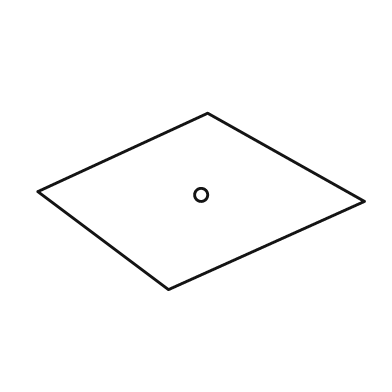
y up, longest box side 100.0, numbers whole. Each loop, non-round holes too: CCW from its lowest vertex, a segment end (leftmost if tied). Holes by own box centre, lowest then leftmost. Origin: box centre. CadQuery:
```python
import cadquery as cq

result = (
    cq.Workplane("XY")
    .moveTo(-10.0, -27.0)
    .lineTo(50.0, 0.0)
    .lineTo(2.0, 27.0)
    .lineTo(-50.0, 3.0)
    .close()
    .moveTo(0.0, 2.0)
    .circle(2.0)
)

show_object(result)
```